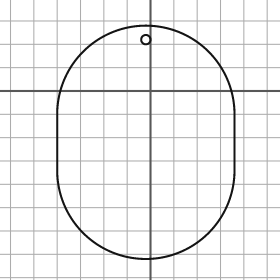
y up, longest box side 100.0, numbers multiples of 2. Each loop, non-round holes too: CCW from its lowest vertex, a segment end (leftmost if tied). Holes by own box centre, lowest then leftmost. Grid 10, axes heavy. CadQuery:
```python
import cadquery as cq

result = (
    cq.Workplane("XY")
    .moveTo(-40.0, -34.0)
    .threePointArc((-2.0, -72.0), (36.0, -34.0))
    .lineTo(36.0, -10.0)
    .threePointArc((-2.0, 28.0), (-40.0, -10.0))
    .close()
    .moveTo(-2.0, 22.0)
    .circle(2.0)
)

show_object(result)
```